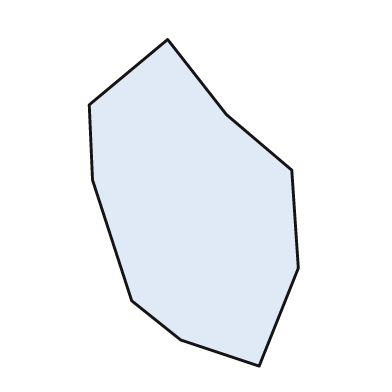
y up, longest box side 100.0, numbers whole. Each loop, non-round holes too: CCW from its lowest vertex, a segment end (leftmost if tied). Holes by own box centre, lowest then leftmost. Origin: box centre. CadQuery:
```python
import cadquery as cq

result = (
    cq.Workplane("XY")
    .moveTo(20.0, -50.0)
    .lineTo(32.0, -20.0)
    .lineTo(30.0, 10.0)
    .lineTo(10.0, 27.0)
    .lineTo(-8.0, 50.0)
    .lineTo(-32.0, 30.0)
    .lineTo(-31.0, 7.0)
    .lineTo(-19.0, -30.0)
    .lineTo(-4.0, -42.0)
    .close()
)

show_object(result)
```